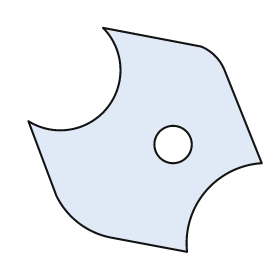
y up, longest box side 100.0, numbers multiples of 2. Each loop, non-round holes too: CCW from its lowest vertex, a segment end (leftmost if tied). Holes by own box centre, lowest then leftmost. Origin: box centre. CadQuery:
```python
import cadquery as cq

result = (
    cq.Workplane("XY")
    .moveTo(18.0, -48.0)
    .threePointArc((26.0, -22.0), (50.0, -10.0))
    .lineTo(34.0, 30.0)
    .threePointArc((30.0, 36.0), (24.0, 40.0))
    .lineTo(-18.0, 48.0)
    .threePointArc((-16.0, 14.0), (-50.0, 8.0))
    .lineTo(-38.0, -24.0)
    .threePointArc((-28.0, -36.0), (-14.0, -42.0))
    .close()
    .moveTo(12.0, -2.0)
    .circle(8.0)
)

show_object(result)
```